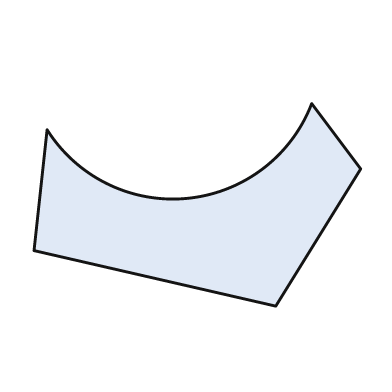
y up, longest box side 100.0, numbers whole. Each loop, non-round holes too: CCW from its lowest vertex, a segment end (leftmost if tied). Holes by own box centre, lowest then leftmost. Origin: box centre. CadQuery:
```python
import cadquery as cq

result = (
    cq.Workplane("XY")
    .moveTo(24.0, -31.0)
    .lineTo(50.0, 11.0)
    .lineTo(35.0, 31.0)
    .threePointArc((-3.0, 2.0), (-46.0, 23.0))
    .lineTo(-50.0, -14.0)
    .close()
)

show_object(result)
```